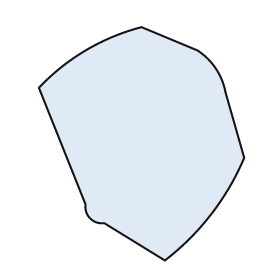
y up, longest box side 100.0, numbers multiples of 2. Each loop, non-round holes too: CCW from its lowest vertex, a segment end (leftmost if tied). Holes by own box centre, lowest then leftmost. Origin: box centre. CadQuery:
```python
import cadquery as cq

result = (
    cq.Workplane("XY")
    .moveTo(10.0, -50.0)
    .threePointArc((30.0, -30.0), (44.0, -6.0))
    .lineTo(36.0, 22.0)
    .threePointArc((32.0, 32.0), (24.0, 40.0))
    .lineTo(0.0, 50.0)
    .threePointArc((-24.0, 40.0), (-44.0, 24.0))
    .lineTo(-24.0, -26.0)
    .threePointArc((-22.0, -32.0), (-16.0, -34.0))
    .close()
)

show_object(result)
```